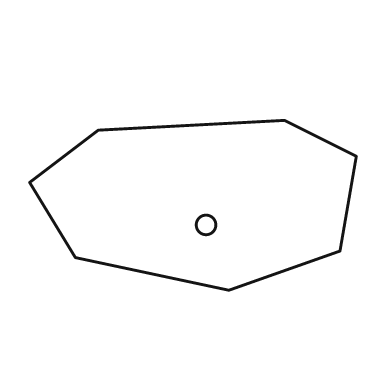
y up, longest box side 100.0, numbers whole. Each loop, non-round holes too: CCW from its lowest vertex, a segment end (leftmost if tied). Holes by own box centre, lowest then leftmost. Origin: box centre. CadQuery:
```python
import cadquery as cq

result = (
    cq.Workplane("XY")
    .moveTo(11.0, -26.0)
    .lineTo(45.0, -14.0)
    .lineTo(50.0, 15.0)
    .lineTo(28.0, 26.0)
    .lineTo(-29.0, 23.0)
    .lineTo(-50.0, 7.0)
    .lineTo(-36.0, -16.0)
    .close()
    .moveTo(4.0, -6.0)
    .circle(3.0)
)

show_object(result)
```